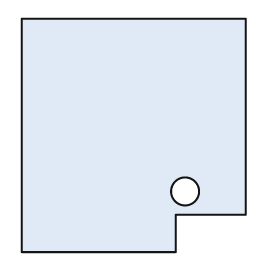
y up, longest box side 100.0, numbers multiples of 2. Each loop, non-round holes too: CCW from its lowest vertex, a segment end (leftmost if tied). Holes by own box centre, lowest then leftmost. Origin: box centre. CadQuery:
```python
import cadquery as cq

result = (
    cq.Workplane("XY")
    .moveTo(-48.0, -50.0)
    .lineTo(18.0, -50.0)
    .lineTo(18.0, -34.0)
    .lineTo(48.0, -34.0)
    .lineTo(48.0, 50.0)
    .lineTo(-48.0, 50.0)
    .close()
    .moveTo(22.0, -24.0)
    .circle(6.0)
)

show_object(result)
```